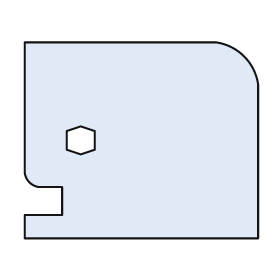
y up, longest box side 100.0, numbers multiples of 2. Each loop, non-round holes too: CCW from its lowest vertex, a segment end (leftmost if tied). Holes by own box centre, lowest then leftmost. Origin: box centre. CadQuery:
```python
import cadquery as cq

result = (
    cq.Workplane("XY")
    .moveTo(-50.0, -42.0)
    .lineTo(50.0, -42.0)
    .lineTo(50.0, 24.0)
    .threePointArc((44.0, 36.0), (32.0, 42.0))
    .lineTo(-50.0, 42.0)
    .lineTo(-50.0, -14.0)
    .threePointArc((-48.0, -18.0), (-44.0, -20.0))
    .lineTo(-34.0, -20.0)
    .lineTo(-34.0, -32.0)
    .lineTo(-50.0, -32.0)
    .close()
    .moveTo(-26.0, -6.0)
    .lineTo(-20.0, -4.0)
    .lineTo(-20.0, 4.0)
    .lineTo(-26.0, 6.0)
    .lineTo(-32.0, 4.0)
    .lineTo(-32.0, -4.0)
    .close()
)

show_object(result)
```